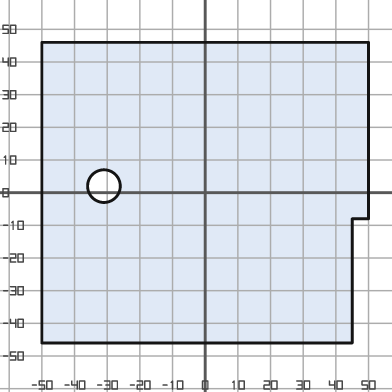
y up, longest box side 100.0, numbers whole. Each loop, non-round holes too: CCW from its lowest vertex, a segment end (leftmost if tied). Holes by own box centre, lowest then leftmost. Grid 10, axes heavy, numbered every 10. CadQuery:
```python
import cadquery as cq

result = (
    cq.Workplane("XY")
    .moveTo(-50.0, -46.0)
    .lineTo(45.0, -46.0)
    .lineTo(45.0, -8.0)
    .lineTo(50.0, -8.0)
    .lineTo(50.0, 46.0)
    .lineTo(-50.0, 46.0)
    .close()
    .moveTo(-31.0, 2.0)
    .circle(5.0)
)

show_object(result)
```